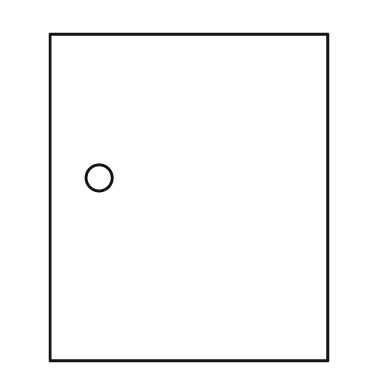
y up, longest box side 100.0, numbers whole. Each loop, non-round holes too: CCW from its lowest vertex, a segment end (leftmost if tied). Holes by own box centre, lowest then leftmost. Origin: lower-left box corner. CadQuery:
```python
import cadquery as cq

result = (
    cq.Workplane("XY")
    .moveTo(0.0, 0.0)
    .lineTo(85.0, 0.0)
    .lineTo(85.0, 100.0)
    .lineTo(0.0, 100.0)
    .close()
    .moveTo(15.0, 56.0)
    .circle(4.0)
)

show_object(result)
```